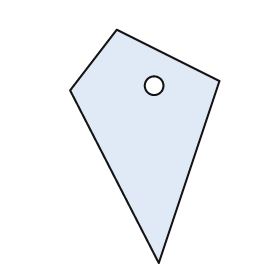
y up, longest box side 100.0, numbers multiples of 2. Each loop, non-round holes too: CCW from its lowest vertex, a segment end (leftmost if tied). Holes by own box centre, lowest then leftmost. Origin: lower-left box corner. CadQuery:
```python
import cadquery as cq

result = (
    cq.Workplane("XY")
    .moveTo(38.0, 0.0)
    .lineTo(64.0, 78.0)
    .lineTo(20.0, 100.0)
    .lineTo(0.0, 74.0)
    .close()
    .moveTo(36.0, 76.0)
    .circle(4.0)
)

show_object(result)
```